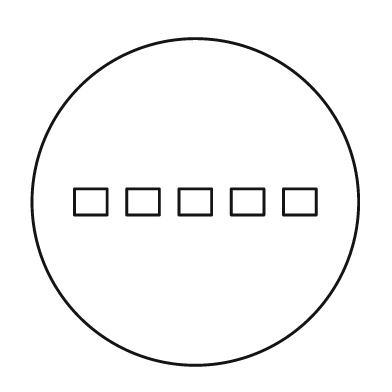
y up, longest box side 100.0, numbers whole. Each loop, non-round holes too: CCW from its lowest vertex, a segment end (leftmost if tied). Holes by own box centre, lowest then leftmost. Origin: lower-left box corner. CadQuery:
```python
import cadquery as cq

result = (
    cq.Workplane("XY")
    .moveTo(50.0, 50.0)
    .circle(50.0)
    .moveTo(13.0, 46.0)
    .lineTo(23.0, 46.0)
    .lineTo(23.0, 54.0)
    .lineTo(13.0, 54.0)
    .close()
    .moveTo(29.0, 46.0)
    .lineTo(39.0, 46.0)
    .lineTo(39.0, 54.0)
    .lineTo(29.0, 54.0)
    .close()
    .moveTo(45.0, 46.0)
    .lineTo(55.0, 46.0)
    .lineTo(55.0, 54.0)
    .lineTo(45.0, 54.0)
    .close()
    .moveTo(61.0, 46.0)
    .lineTo(71.0, 46.0)
    .lineTo(71.0, 54.0)
    .lineTo(61.0, 54.0)
    .close()
    .moveTo(77.0, 46.0)
    .lineTo(87.0, 46.0)
    .lineTo(87.0, 54.0)
    .lineTo(77.0, 54.0)
    .close()
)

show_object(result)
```